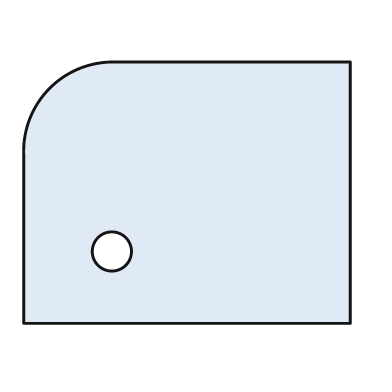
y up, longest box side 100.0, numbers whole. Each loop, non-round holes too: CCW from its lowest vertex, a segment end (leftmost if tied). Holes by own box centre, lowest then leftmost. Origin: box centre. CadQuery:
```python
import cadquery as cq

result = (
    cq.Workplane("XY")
    .moveTo(-50.0, -40.0)
    .lineTo(50.0, -40.0)
    .lineTo(50.0, 40.0)
    .lineTo(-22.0, 40.0)
    .threePointArc((-42.0, 32.0), (-50.0, 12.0))
    .close()
    .moveTo(-23.0, -18.0)
    .circle(6.0)
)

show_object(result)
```